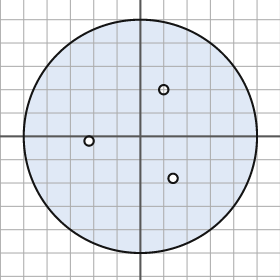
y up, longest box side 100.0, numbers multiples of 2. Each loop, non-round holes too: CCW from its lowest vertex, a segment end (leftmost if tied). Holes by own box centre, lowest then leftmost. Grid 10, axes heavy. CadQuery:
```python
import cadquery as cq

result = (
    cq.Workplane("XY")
    .moveTo(0.0, 0.0)
    .circle(50.0)
    .moveTo(14.0, -18.0)
    .circle(2.0)
    .moveTo(-22.0, -2.0)
    .circle(2.0)
    .moveTo(10.0, 20.0)
    .circle(2.0)
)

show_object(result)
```